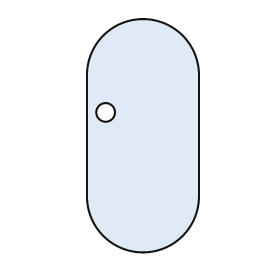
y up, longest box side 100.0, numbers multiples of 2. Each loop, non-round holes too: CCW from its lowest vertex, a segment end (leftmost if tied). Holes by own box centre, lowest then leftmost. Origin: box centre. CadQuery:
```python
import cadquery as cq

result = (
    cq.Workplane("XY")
    .moveTo(-24.0, -26.0)
    .threePointArc((0.0, -50.0), (24.0, -26.0))
    .lineTo(24.0, 26.0)
    .threePointArc((0.0, 50.0), (-24.0, 26.0))
    .close()
    .moveTo(-16.0, 10.0)
    .circle(4.0)
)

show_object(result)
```